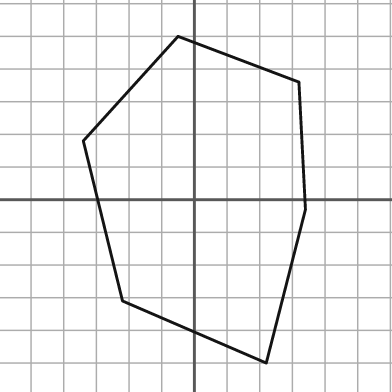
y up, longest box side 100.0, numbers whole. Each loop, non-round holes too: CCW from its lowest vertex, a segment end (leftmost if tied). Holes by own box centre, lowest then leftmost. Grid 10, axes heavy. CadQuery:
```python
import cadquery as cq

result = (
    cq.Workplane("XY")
    .moveTo(22.0, -50.0)
    .lineTo(34.0, -3.0)
    .lineTo(32.0, 36.0)
    .lineTo(-5.0, 50.0)
    .lineTo(-34.0, 18.0)
    .lineTo(-22.0, -31.0)
    .close()
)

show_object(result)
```